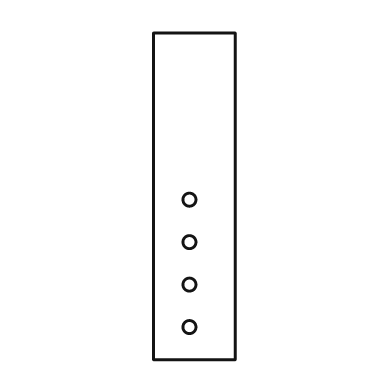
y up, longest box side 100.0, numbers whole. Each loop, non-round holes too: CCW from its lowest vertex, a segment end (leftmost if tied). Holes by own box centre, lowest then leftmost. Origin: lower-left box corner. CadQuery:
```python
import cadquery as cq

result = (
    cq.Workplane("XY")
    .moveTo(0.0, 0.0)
    .lineTo(25.0, 0.0)
    .lineTo(25.0, 100.0)
    .lineTo(0.0, 100.0)
    .close()
    .moveTo(11.0, 10.0)
    .circle(2.0)
    .moveTo(11.0, 23.0)
    .circle(2.0)
    .moveTo(11.0, 36.0)
    .circle(2.0)
    .moveTo(11.0, 49.0)
    .circle(2.0)
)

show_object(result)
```